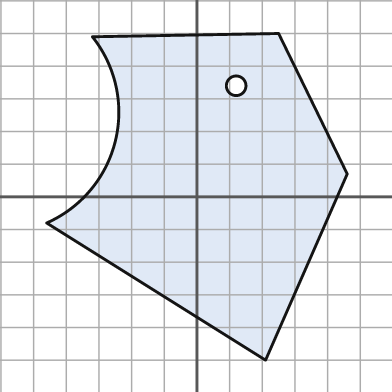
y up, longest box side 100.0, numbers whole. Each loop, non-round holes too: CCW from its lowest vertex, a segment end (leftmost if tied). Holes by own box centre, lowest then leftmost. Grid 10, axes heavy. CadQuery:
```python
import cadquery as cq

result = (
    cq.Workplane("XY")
    .moveTo(21.0, -50.0)
    .lineTo(46.0, 7.0)
    .lineTo(25.0, 50.0)
    .lineTo(-32.0, 49.0)
    .threePointArc((-25.0, 17.0), (-46.0, -8.0))
    .close()
    .moveTo(12.0, 34.0)
    .circle(3.0)
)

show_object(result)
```